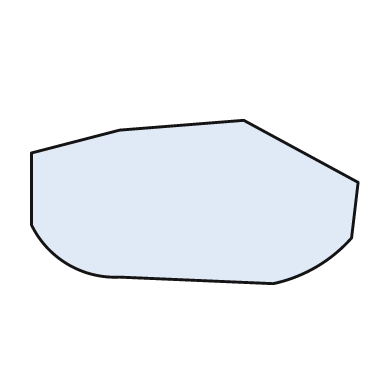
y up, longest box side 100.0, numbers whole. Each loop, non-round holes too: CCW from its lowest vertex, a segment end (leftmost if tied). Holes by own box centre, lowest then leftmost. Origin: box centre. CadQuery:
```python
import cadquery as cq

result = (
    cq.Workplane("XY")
    .moveTo(24.0, -25.0)
    .threePointArc((37.0, -20.0), (48.0, -11.0))
    .lineTo(50.0, 6.0)
    .lineTo(15.0, 25.0)
    .lineTo(-23.0, 22.0)
    .lineTo(-50.0, 15.0)
    .lineTo(-50.0, -7.0)
    .threePointArc((-39.0, -19.0), (-23.0, -23.0))
    .close()
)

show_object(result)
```